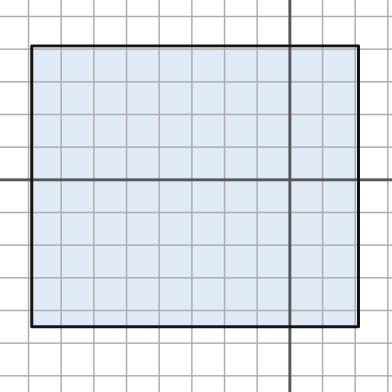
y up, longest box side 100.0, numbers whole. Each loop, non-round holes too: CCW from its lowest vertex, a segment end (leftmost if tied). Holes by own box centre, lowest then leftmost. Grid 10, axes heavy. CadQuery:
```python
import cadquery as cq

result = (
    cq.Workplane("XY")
    .moveTo(-79.0, -45.0)
    .lineTo(21.0, -45.0)
    .lineTo(21.0, 41.0)
    .lineTo(-79.0, 41.0)
    .close()
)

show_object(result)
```